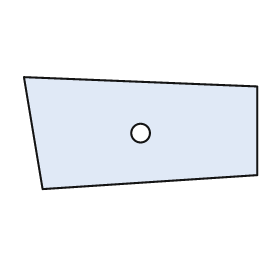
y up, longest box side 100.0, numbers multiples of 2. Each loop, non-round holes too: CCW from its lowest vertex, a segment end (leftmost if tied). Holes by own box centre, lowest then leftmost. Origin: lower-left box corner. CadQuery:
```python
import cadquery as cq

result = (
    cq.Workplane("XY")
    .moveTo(8.0, 0.0)
    .lineTo(100.0, 6.0)
    .lineTo(100.0, 44.0)
    .lineTo(0.0, 48.0)
    .close()
    .moveTo(50.0, 24.0)
    .circle(4.0)
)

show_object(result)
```